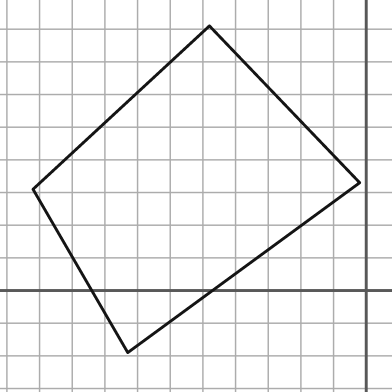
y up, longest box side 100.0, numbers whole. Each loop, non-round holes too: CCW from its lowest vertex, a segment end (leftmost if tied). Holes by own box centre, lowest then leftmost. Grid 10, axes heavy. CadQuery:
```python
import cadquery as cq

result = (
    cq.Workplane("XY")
    .moveTo(-73.0, -19.0)
    .lineTo(-2.0, 33.0)
    .lineTo(-48.0, 81.0)
    .lineTo(-102.0, 31.0)
    .close()
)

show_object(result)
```